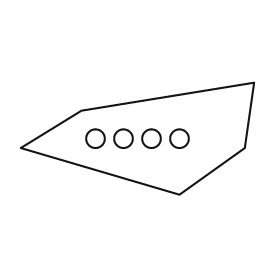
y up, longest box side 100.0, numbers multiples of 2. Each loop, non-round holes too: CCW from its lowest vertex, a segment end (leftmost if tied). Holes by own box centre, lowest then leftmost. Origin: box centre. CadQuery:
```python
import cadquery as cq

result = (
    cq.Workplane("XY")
    .moveTo(18.0, -24.0)
    .lineTo(46.0, -4.0)
    .lineTo(50.0, 24.0)
    .lineTo(-24.0, 12.0)
    .lineTo(-50.0, -4.0)
    .close()
    .moveTo(-18.0, 0.0)
    .circle(4.0)
    .moveTo(-6.0, 0.0)
    .circle(4.0)
    .moveTo(6.0, 0.0)
    .circle(4.0)
    .moveTo(18.0, 0.0)
    .circle(4.0)
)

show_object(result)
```